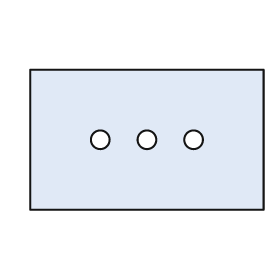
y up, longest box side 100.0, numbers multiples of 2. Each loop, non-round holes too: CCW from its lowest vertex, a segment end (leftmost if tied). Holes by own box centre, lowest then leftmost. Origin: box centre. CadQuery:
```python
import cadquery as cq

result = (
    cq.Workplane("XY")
    .moveTo(-50.0, -30.0)
    .lineTo(50.0, -30.0)
    .lineTo(50.0, 30.0)
    .lineTo(-50.0, 30.0)
    .close()
    .moveTo(-20.0, 0.0)
    .circle(4.0)
    .moveTo(0.0, 0.0)
    .circle(4.0)
    .moveTo(20.0, 0.0)
    .circle(4.0)
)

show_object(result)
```